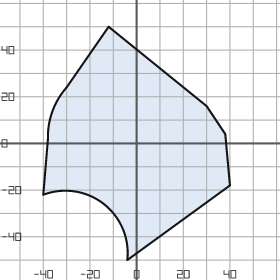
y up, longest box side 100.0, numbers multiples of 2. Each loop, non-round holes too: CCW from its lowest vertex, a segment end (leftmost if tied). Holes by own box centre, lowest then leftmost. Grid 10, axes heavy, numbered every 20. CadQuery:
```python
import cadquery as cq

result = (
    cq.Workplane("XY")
    .moveTo(-4.0, -50.0)
    .lineTo(40.0, -18.0)
    .lineTo(38.0, 4.0)
    .lineTo(30.0, 16.0)
    .lineTo(-12.0, 50.0)
    .lineTo(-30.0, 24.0)
    .threePointArc((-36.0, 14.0), (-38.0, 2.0))
    .lineTo(-40.0, -22.0)
    .threePointArc((-14.0, -26.0), (-4.0, -50.0))
    .close()
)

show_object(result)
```